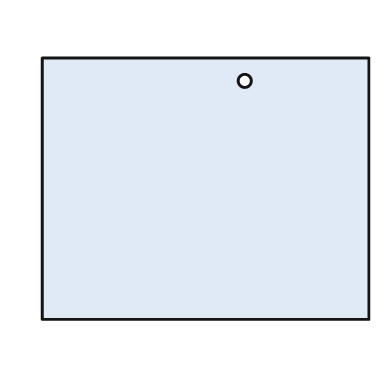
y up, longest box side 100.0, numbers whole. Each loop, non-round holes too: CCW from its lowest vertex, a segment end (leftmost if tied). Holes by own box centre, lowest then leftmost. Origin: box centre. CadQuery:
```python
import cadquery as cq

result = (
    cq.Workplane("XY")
    .moveTo(-50.0, -40.0)
    .lineTo(50.0, -40.0)
    .lineTo(50.0, 40.0)
    .lineTo(-50.0, 40.0)
    .close()
    .moveTo(12.0, 33.0)
    .circle(2.0)
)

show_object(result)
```